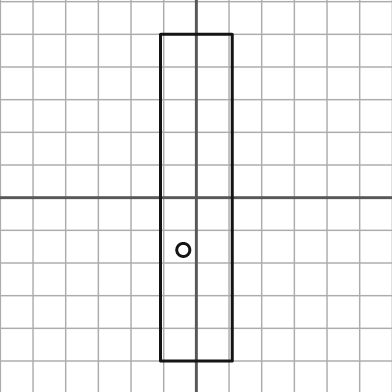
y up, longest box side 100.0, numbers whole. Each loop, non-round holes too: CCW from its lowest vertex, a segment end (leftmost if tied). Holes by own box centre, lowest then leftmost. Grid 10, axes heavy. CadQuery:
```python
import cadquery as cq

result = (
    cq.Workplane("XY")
    .moveTo(-11.0, -50.0)
    .lineTo(11.0, -50.0)
    .lineTo(11.0, 50.0)
    .lineTo(-11.0, 50.0)
    .close()
    .moveTo(-4.0, -16.0)
    .circle(2.0)
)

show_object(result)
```